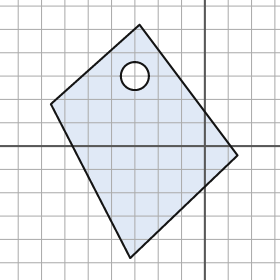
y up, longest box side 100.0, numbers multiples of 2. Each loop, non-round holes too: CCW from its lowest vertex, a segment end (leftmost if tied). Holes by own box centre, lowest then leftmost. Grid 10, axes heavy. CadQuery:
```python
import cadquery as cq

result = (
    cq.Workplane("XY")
    .moveTo(-32.0, -48.0)
    .lineTo(14.0, -4.0)
    .lineTo(-28.0, 52.0)
    .lineTo(-66.0, 18.0)
    .close()
    .moveTo(-30.0, 30.0)
    .circle(6.0)
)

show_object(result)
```